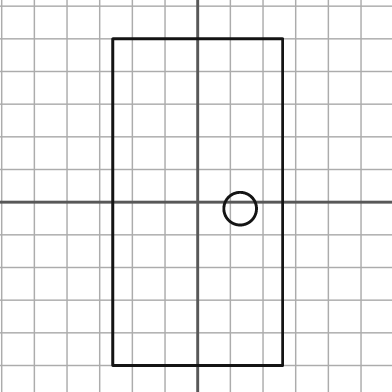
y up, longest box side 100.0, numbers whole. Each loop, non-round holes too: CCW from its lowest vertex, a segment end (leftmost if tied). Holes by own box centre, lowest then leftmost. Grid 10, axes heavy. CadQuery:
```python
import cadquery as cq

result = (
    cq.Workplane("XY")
    .moveTo(-26.0, -50.0)
    .lineTo(26.0, -50.0)
    .lineTo(26.0, 50.0)
    .lineTo(-26.0, 50.0)
    .close()
    .moveTo(13.0, -2.0)
    .circle(5.0)
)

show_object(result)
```